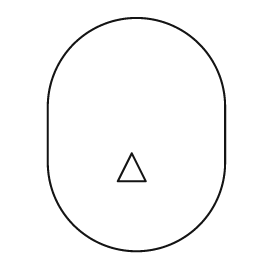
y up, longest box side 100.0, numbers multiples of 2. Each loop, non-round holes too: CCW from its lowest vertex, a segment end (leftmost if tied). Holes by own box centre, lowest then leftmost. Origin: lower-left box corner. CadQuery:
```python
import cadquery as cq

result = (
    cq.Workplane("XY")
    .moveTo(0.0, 38.0)
    .threePointArc((38.0, 0.0), (76.0, 38.0))
    .lineTo(76.0, 62.0)
    .threePointArc((38.0, 100.0), (0.0, 62.0))
    .close()
    .moveTo(30.0, 30.0)
    .lineTo(42.0, 30.0)
    .lineTo(36.0, 42.0)
    .close()
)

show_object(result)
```